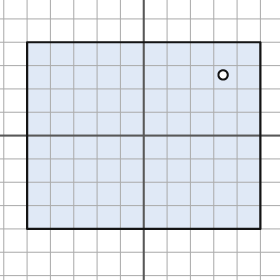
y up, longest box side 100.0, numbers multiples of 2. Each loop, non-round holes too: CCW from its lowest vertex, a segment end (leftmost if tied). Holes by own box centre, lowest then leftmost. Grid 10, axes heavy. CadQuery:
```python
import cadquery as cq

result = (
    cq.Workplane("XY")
    .moveTo(-50.0, -40.0)
    .lineTo(50.0, -40.0)
    .lineTo(50.0, 40.0)
    .lineTo(-50.0, 40.0)
    .close()
    .moveTo(34.0, 26.0)
    .circle(2.0)
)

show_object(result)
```